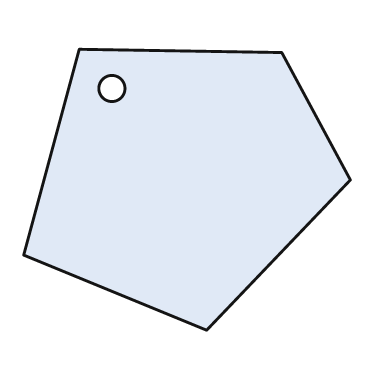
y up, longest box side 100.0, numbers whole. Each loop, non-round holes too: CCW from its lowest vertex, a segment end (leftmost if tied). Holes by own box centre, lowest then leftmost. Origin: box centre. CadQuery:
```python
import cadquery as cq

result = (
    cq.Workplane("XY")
    .moveTo(6.0, -43.0)
    .lineTo(50.0, 3.0)
    .lineTo(29.0, 42.0)
    .lineTo(-33.0, 43.0)
    .lineTo(-50.0, -20.0)
    .close()
    .moveTo(-23.0, 31.0)
    .circle(4.0)
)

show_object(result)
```